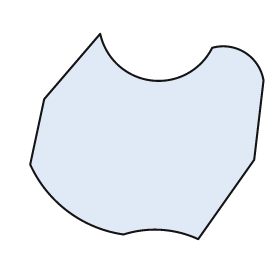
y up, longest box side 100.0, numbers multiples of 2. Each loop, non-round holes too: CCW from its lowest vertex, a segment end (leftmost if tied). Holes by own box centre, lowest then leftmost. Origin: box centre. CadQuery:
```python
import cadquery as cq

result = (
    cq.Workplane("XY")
    .moveTo(22.0, -44.0)
    .lineTo(46.0, -10.0)
    .lineTo(50.0, 24.0)
    .threePointArc((42.0, 36.0), (28.0, 38.0))
    .threePointArc((2.0, 24.0), (-20.0, 44.0))
    .lineTo(-44.0, 16.0)
    .lineTo(-50.0, -12.0)
    .threePointArc((-34.0, -32.0), (-10.0, -42.0))
    .threePointArc((6.0, -40.0), (22.0, -44.0))
    .close()
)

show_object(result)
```